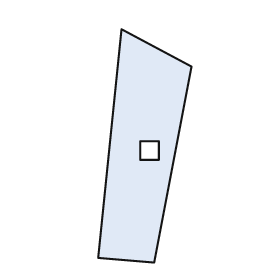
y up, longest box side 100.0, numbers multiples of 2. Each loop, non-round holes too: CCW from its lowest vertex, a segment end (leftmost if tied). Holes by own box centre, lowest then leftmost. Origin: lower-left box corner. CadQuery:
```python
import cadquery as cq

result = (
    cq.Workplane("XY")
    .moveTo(24.0, 0.0)
    .lineTo(40.0, 84.0)
    .lineTo(10.0, 100.0)
    .lineTo(0.0, 2.0)
    .close()
    .moveTo(18.0, 44.0)
    .lineTo(26.0, 44.0)
    .lineTo(26.0, 52.0)
    .lineTo(18.0, 52.0)
    .close()
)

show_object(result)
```